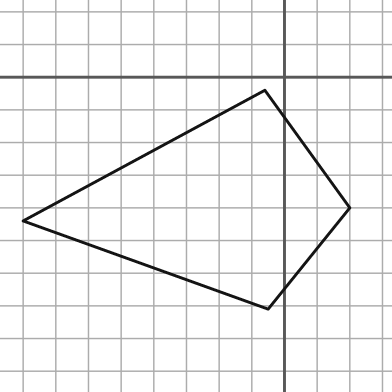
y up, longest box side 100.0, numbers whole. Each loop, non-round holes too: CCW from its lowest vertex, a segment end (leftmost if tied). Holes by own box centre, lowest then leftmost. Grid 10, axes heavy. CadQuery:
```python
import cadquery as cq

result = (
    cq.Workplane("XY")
    .moveTo(-5.0, -71.0)
    .lineTo(20.0, -40.0)
    .lineTo(-6.0, -4.0)
    .lineTo(-80.0, -44.0)
    .close()
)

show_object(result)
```